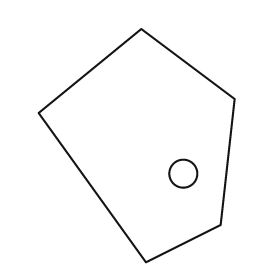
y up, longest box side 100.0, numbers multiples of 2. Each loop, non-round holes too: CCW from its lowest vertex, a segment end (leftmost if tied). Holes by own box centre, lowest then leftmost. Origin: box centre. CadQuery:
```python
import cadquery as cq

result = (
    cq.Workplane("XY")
    .moveTo(4.0, -50.0)
    .lineTo(36.0, -34.0)
    .lineTo(42.0, 20.0)
    .lineTo(2.0, 50.0)
    .lineTo(-42.0, 14.0)
    .close()
    .moveTo(20.0, -12.0)
    .circle(6.0)
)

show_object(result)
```